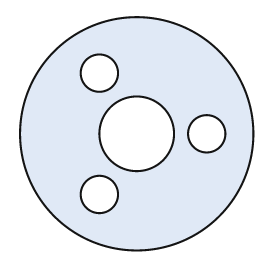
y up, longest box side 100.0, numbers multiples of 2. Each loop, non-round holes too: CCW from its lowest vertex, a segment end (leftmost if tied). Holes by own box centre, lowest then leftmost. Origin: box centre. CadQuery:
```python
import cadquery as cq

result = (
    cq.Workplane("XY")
    .moveTo(0.0, 0.0)
    .circle(50.0)
    .moveTo(-16.0, -26.0)
    .circle(8.0)
    .moveTo(0.0, 0.0)
    .circle(16.0)
    .moveTo(30.0, 0.0)
    .circle(8.0)
    .moveTo(-16.0, 26.0)
    .circle(8.0)
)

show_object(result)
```